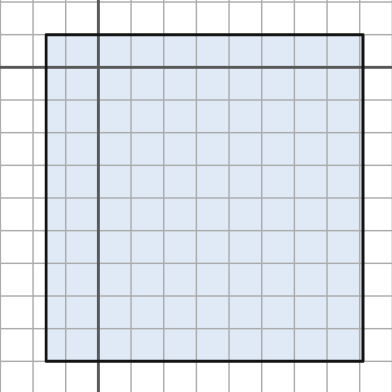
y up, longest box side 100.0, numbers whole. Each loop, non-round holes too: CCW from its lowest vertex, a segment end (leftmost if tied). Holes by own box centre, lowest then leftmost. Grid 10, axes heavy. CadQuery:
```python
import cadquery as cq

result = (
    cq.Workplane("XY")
    .moveTo(-16.0, -90.0)
    .lineTo(81.0, -90.0)
    .lineTo(81.0, 10.0)
    .lineTo(-16.0, 10.0)
    .close()
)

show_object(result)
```